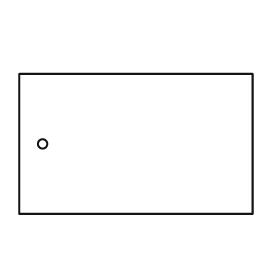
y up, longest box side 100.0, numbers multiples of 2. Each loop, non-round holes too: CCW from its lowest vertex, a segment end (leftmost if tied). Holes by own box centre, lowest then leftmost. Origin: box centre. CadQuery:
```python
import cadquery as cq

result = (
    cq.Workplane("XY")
    .moveTo(-50.0, -30.0)
    .lineTo(50.0, -30.0)
    .lineTo(50.0, 30.0)
    .lineTo(-50.0, 30.0)
    .close()
    .moveTo(-40.0, 0.0)
    .circle(2.0)
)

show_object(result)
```